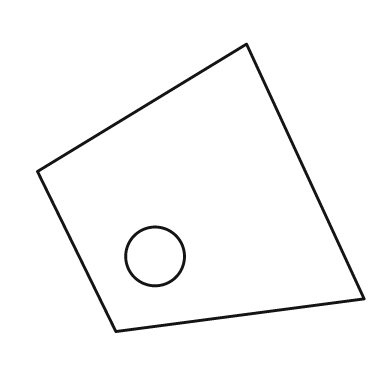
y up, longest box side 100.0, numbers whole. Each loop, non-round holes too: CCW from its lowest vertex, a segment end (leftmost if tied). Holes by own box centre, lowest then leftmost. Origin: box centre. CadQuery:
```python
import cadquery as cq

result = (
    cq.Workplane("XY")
    .moveTo(-26.0, -44.0)
    .lineTo(50.0, -34.0)
    .lineTo(14.0, 44.0)
    .lineTo(-50.0, 5.0)
    .close()
    .moveTo(-14.0, -21.0)
    .circle(9.0)
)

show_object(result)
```